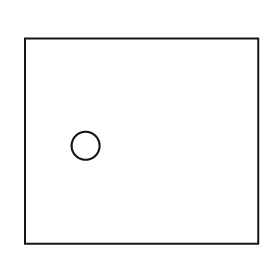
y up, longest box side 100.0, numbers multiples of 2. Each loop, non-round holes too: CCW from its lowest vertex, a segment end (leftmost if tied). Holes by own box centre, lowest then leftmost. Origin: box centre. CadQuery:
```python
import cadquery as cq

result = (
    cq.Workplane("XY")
    .moveTo(-50.0, -44.0)
    .lineTo(50.0, -44.0)
    .lineTo(50.0, 44.0)
    .lineTo(-50.0, 44.0)
    .close()
    .moveTo(-24.0, -2.0)
    .circle(6.0)
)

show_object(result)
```